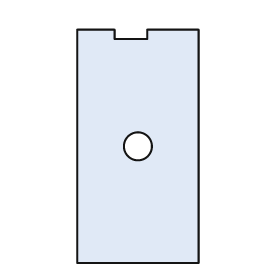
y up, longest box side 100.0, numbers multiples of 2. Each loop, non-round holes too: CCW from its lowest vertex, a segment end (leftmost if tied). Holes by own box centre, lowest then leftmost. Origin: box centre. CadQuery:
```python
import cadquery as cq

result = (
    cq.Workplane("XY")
    .moveTo(-26.0, -50.0)
    .lineTo(26.0, -50.0)
    .lineTo(26.0, 50.0)
    .lineTo(4.0, 50.0)
    .lineTo(4.0, 46.0)
    .lineTo(-10.0, 46.0)
    .lineTo(-10.0, 50.0)
    .lineTo(-26.0, 50.0)
    .close()
    .moveTo(0.0, 0.0)
    .circle(6.0)
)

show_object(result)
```